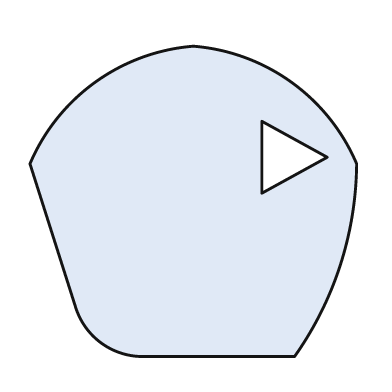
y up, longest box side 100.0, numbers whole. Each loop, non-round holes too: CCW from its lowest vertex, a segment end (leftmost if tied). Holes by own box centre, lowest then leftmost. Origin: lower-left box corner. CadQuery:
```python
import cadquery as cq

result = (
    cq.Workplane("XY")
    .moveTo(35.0, 0.0)
    .lineTo(81.0, 0.0)
    .threePointArc((95.0, 28.0), (100.0, 59.0))
    .threePointArc((80.0, 84.0), (50.0, 95.0))
    .threePointArc((20.0, 84.0), (0.0, 59.0))
    .lineTo(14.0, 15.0)
    .threePointArc((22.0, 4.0), (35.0, 0.0))
    .close()
    .moveTo(71.0, 50.0)
    .lineTo(91.0, 61.0)
    .lineTo(71.0, 72.0)
    .close()
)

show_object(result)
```